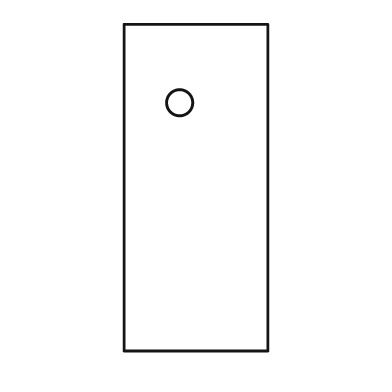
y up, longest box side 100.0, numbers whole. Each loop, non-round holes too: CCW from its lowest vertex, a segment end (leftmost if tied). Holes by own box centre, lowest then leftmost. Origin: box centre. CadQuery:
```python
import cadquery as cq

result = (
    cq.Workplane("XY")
    .moveTo(-22.0, -50.0)
    .lineTo(22.0, -50.0)
    .lineTo(22.0, 50.0)
    .lineTo(-22.0, 50.0)
    .close()
    .moveTo(-5.0, 26.0)
    .circle(4.0)
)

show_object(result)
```